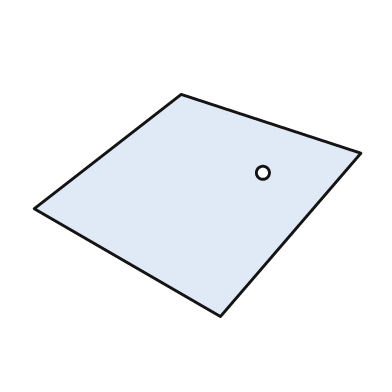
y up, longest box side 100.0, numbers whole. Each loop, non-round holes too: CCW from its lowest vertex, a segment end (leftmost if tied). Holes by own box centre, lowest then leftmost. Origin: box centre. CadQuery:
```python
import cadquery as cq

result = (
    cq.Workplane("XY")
    .moveTo(7.0, -34.0)
    .lineTo(50.0, 16.0)
    .lineTo(-5.0, 34.0)
    .lineTo(-50.0, -1.0)
    .close()
    .moveTo(20.0, 10.0)
    .circle(2.0)
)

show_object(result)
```